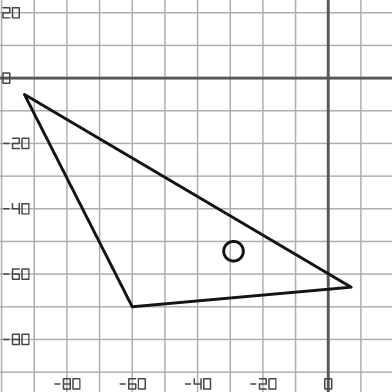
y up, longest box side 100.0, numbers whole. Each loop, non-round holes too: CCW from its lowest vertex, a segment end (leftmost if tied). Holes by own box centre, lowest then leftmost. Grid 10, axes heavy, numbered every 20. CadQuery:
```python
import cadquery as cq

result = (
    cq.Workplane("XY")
    .moveTo(-60.0, -70.0)
    .lineTo(7.0, -64.0)
    .lineTo(-93.0, -5.0)
    .close()
    .moveTo(-29.0, -53.0)
    .circle(3.0)
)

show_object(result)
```